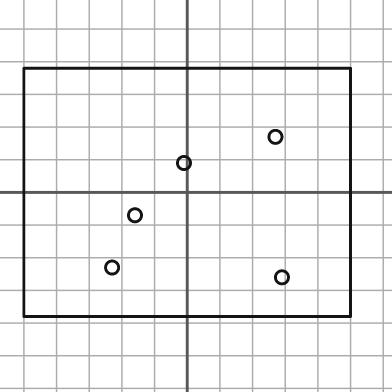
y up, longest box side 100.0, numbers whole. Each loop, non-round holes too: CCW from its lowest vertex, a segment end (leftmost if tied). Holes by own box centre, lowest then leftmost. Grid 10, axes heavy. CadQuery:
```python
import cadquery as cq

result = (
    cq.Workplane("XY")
    .moveTo(-50.0, -38.0)
    .lineTo(50.0, -38.0)
    .lineTo(50.0, 38.0)
    .lineTo(-50.0, 38.0)
    .close()
    .moveTo(29.0, -26.0)
    .circle(2.0)
    .moveTo(-23.0, -23.0)
    .circle(2.0)
    .moveTo(-16.0, -7.0)
    .circle(2.0)
    .moveTo(-1.0, 9.0)
    .circle(2.0)
    .moveTo(27.0, 17.0)
    .circle(2.0)
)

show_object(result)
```